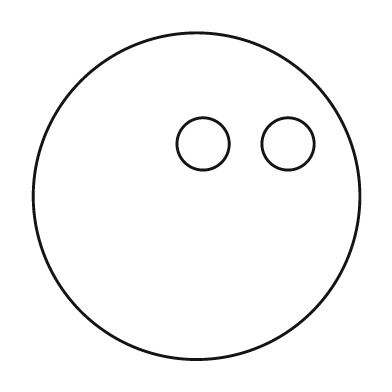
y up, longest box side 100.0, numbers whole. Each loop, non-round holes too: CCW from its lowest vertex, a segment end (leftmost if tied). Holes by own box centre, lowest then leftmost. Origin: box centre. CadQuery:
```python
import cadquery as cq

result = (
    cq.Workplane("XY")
    .moveTo(0.0, 0.0)
    .circle(50.0)
    .moveTo(2.0, 16.0)
    .circle(8.0)
    .moveTo(28.0, 16.0)
    .circle(8.0)
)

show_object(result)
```